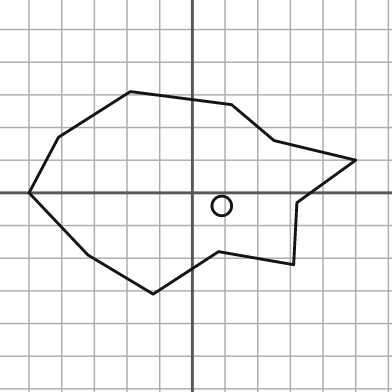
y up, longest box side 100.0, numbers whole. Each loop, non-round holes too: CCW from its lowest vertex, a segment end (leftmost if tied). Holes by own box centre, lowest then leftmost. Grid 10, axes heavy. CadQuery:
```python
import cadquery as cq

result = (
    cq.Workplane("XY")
    .moveTo(-12.0, -31.0)
    .lineTo(8.0, -18.0)
    .lineTo(31.0, -22.0)
    .lineTo(32.0, -3.0)
    .lineTo(50.0, 10.0)
    .lineTo(25.0, 16.0)
    .lineTo(12.0, 27.0)
    .lineTo(-19.0, 31.0)
    .lineTo(-41.0, 17.0)
    .lineTo(-50.0, 0.0)
    .lineTo(-32.0, -19.0)
    .close()
    .moveTo(9.0, -4.0)
    .circle(3.0)
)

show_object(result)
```